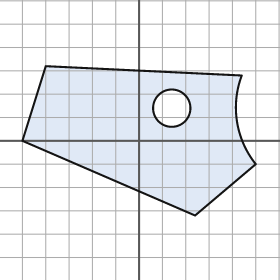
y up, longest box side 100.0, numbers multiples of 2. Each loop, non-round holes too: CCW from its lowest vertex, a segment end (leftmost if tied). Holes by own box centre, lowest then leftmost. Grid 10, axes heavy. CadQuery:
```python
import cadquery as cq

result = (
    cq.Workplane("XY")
    .moveTo(24.0, -32.0)
    .lineTo(50.0, -10.0)
    .threePointArc((42.0, 8.0), (44.0, 28.0))
    .lineTo(-40.0, 32.0)
    .lineTo(-50.0, 0.0)
    .close()
    .moveTo(14.0, 14.0)
    .circle(8.0)
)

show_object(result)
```